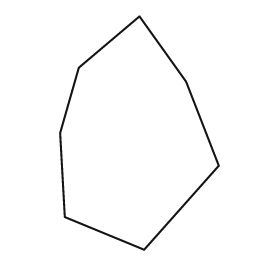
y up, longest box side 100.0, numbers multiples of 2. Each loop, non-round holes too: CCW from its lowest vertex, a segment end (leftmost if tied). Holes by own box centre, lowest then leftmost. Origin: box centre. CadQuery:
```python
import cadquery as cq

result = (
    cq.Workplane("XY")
    .moveTo(2.0, -50.0)
    .lineTo(34.0, -14.0)
    .lineTo(20.0, 22.0)
    .lineTo(0.0, 50.0)
    .lineTo(-26.0, 28.0)
    .lineTo(-34.0, 0.0)
    .lineTo(-32.0, -36.0)
    .close()
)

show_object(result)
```